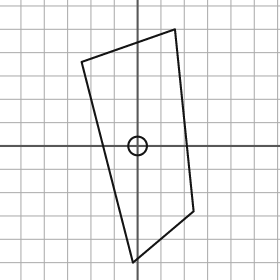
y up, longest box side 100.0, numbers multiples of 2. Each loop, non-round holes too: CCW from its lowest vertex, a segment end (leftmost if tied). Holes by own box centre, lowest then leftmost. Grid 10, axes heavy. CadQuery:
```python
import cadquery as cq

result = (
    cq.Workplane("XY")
    .moveTo(-2.0, -50.0)
    .lineTo(24.0, -28.0)
    .lineTo(16.0, 50.0)
    .lineTo(-24.0, 36.0)
    .close()
    .moveTo(0.0, 0.0)
    .circle(4.0)
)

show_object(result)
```